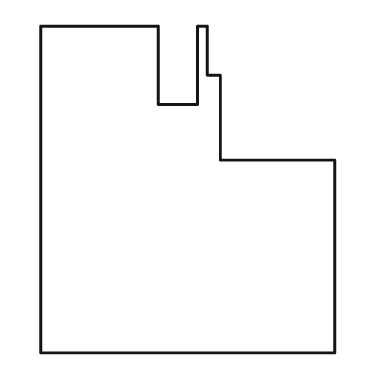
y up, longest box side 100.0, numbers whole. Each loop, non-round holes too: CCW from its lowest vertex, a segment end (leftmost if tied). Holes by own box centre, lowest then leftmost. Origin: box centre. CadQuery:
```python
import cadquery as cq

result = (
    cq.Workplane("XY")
    .moveTo(-45.0, -50.0)
    .lineTo(45.0, -50.0)
    .lineTo(45.0, 9.0)
    .lineTo(10.0, 9.0)
    .lineTo(10.0, 35.0)
    .lineTo(6.0, 35.0)
    .lineTo(6.0, 50.0)
    .lineTo(3.0, 50.0)
    .lineTo(3.0, 26.0)
    .lineTo(-9.0, 26.0)
    .lineTo(-9.0, 50.0)
    .lineTo(-45.0, 50.0)
    .close()
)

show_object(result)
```